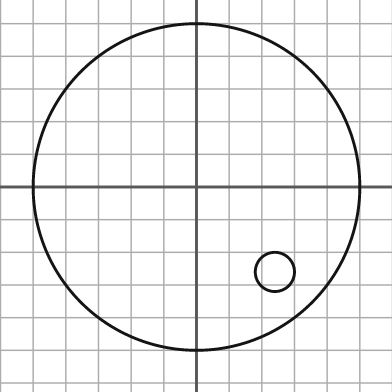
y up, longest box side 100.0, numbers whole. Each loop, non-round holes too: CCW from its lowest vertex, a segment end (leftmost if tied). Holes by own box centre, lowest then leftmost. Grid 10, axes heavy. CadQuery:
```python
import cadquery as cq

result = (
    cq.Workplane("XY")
    .moveTo(0.0, 0.0)
    .circle(50.0)
    .moveTo(24.0, -26.0)
    .circle(6.0)
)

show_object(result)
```